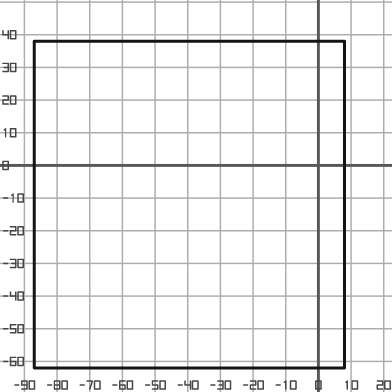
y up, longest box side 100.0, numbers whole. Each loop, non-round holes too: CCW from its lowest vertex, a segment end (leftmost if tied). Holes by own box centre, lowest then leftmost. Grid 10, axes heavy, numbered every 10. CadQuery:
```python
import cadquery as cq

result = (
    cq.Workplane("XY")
    .moveTo(-87.0, -62.0)
    .lineTo(8.0, -62.0)
    .lineTo(8.0, 38.0)
    .lineTo(-87.0, 38.0)
    .close()
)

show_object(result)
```